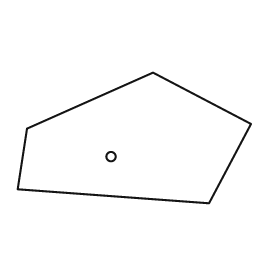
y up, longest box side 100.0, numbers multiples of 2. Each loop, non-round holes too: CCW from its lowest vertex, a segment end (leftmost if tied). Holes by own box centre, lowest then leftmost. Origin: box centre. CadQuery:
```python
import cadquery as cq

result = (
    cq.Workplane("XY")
    .moveTo(32.0, -28.0)
    .lineTo(50.0, 6.0)
    .lineTo(8.0, 28.0)
    .lineTo(-46.0, 4.0)
    .lineTo(-50.0, -22.0)
    .close()
    .moveTo(-10.0, -8.0)
    .circle(2.0)
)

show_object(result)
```